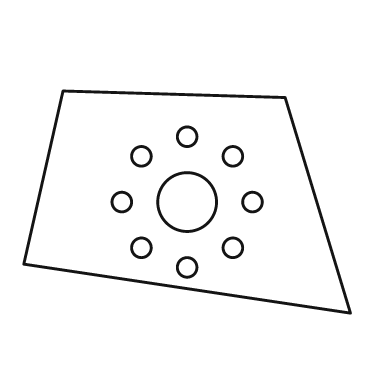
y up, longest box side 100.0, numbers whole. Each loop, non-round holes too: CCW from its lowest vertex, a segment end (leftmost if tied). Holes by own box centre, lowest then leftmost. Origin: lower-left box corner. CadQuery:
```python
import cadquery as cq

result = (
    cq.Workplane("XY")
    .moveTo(100.0, 0.0)
    .lineTo(80.0, 66.0)
    .lineTo(12.0, 68.0)
    .lineTo(0.0, 15.0)
    .close()
    .moveTo(50.0, 14.0)
    .circle(3.0)
    .moveTo(36.0, 20.0)
    .circle(3.0)
    .moveTo(64.0, 20.0)
    .circle(3.0)
    .moveTo(30.0, 34.0)
    .circle(3.0)
    .moveTo(50.0, 34.0)
    .circle(9.0)
    .moveTo(70.0, 34.0)
    .circle(3.0)
    .moveTo(36.0, 48.0)
    .circle(3.0)
    .moveTo(64.0, 48.0)
    .circle(3.0)
    .moveTo(50.0, 54.0)
    .circle(3.0)
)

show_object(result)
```